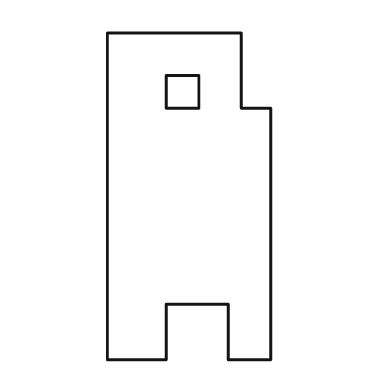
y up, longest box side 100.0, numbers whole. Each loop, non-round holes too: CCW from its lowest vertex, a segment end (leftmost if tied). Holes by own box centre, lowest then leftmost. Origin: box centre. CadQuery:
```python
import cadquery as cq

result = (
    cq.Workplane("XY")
    .moveTo(-25.0, -50.0)
    .lineTo(-7.0, -50.0)
    .lineTo(-7.0, -33.0)
    .lineTo(12.0, -33.0)
    .lineTo(12.0, -50.0)
    .lineTo(25.0, -50.0)
    .lineTo(25.0, 27.0)
    .lineTo(16.0, 27.0)
    .lineTo(16.0, 50.0)
    .lineTo(-25.0, 50.0)
    .close()
    .moveTo(-7.0, 27.0)
    .lineTo(3.0, 27.0)
    .lineTo(3.0, 37.0)
    .lineTo(-7.0, 37.0)
    .close()
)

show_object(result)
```